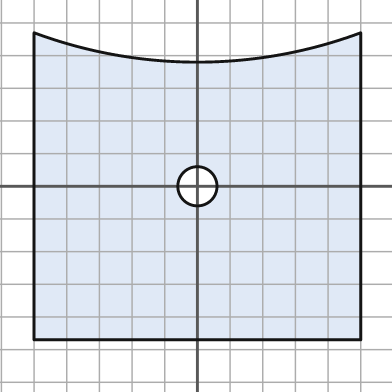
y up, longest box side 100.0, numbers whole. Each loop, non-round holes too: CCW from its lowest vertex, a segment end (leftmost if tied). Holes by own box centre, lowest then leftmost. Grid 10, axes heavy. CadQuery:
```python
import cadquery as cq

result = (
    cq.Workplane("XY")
    .moveTo(-50.0, -47.0)
    .lineTo(50.0, -47.0)
    .lineTo(50.0, 47.0)
    .threePointArc((0.0, 38.0), (-50.0, 47.0))
    .close()
    .moveTo(0.0, 0.0)
    .circle(6.0)
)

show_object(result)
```